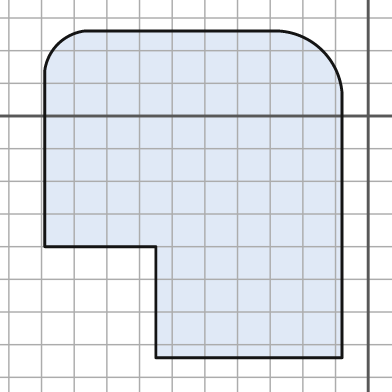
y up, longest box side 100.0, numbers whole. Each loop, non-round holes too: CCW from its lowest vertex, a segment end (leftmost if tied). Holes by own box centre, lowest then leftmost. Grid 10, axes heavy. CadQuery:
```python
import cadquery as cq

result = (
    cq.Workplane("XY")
    .moveTo(-65.0, -74.0)
    .lineTo(-8.0, -74.0)
    .lineTo(-8.0, 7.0)
    .threePointArc((-14.0, 20.0), (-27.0, 26.0))
    .lineTo(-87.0, 26.0)
    .threePointArc((-95.0, 22.0), (-99.0, 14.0))
    .lineTo(-99.0, -40.0)
    .lineTo(-65.0, -40.0)
    .close()
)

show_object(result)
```